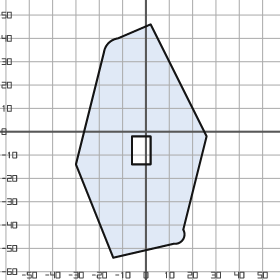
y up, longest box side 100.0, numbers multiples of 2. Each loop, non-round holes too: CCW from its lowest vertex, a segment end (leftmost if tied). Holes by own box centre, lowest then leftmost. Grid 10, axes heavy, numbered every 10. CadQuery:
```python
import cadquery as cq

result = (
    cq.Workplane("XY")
    .moveTo(-14.0, -54.0)
    .lineTo(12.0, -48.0)
    .threePointArc((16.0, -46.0), (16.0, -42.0))
    .lineTo(26.0, -2.0)
    .lineTo(2.0, 46.0)
    .lineTo(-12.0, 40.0)
    .threePointArc((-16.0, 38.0), (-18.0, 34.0))
    .lineTo(-30.0, -14.0)
    .close()
    .moveTo(-6.0, -14.0)
    .lineTo(2.0, -14.0)
    .lineTo(2.0, -2.0)
    .lineTo(-6.0, -2.0)
    .close()
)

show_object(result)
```